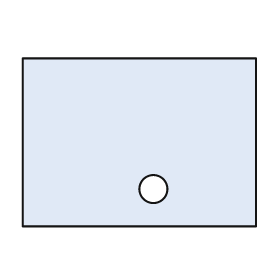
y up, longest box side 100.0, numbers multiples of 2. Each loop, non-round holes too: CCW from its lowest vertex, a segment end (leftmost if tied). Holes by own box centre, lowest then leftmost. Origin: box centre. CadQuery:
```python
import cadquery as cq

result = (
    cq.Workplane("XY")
    .moveTo(-50.0, -36.0)
    .lineTo(50.0, -36.0)
    .lineTo(50.0, 36.0)
    .lineTo(-50.0, 36.0)
    .close()
    .moveTo(6.0, -20.0)
    .circle(6.0)
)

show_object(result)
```